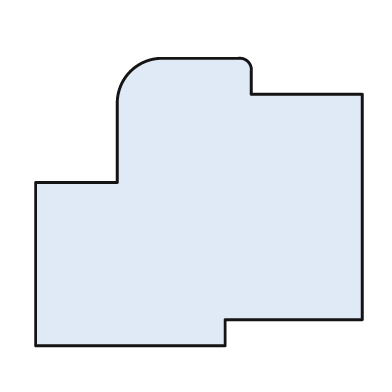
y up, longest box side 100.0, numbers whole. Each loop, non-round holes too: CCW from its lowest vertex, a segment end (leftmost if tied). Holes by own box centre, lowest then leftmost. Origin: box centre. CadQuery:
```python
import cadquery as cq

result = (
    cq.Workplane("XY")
    .moveTo(-50.0, -44.0)
    .lineTo(8.0, -44.0)
    .lineTo(8.0, -36.0)
    .lineTo(50.0, -36.0)
    .lineTo(50.0, 33.0)
    .lineTo(16.0, 33.0)
    .lineTo(16.0, 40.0)
    .threePointArc((15.0, 43.0), (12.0, 44.0))
    .lineTo(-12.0, 44.0)
    .threePointArc((-21.0, 40.0), (-25.0, 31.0))
    .lineTo(-25.0, 6.0)
    .lineTo(-50.0, 6.0)
    .close()
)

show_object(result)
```